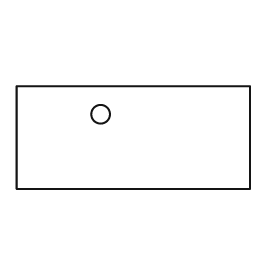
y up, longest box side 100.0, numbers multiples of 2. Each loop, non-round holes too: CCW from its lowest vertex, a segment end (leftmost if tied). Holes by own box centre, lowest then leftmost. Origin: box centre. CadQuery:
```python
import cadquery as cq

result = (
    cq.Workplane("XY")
    .moveTo(-50.0, -22.0)
    .lineTo(50.0, -22.0)
    .lineTo(50.0, 22.0)
    .lineTo(-50.0, 22.0)
    .close()
    .moveTo(-14.0, 10.0)
    .circle(4.0)
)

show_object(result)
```